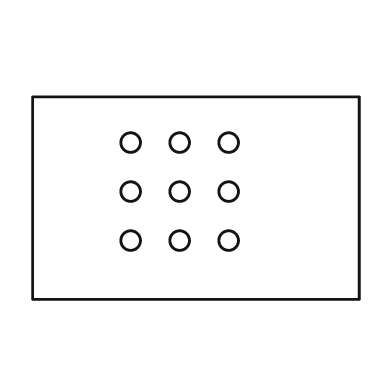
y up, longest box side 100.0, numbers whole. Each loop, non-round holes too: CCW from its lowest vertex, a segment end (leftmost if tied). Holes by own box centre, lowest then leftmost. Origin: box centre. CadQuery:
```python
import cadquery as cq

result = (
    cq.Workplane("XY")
    .moveTo(-50.0, -31.0)
    .lineTo(50.0, -31.0)
    .lineTo(50.0, 31.0)
    .lineTo(-50.0, 31.0)
    .close()
    .moveTo(-20.0, -13.0)
    .circle(3.0)
    .moveTo(-5.0, -13.0)
    .circle(3.0)
    .moveTo(10.0, -13.0)
    .circle(3.0)
    .moveTo(-20.0, 2.0)
    .circle(3.0)
    .moveTo(-5.0, 2.0)
    .circle(3.0)
    .moveTo(10.0, 2.0)
    .circle(3.0)
    .moveTo(-20.0, 17.0)
    .circle(3.0)
    .moveTo(-5.0, 17.0)
    .circle(3.0)
    .moveTo(10.0, 17.0)
    .circle(3.0)
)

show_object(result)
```